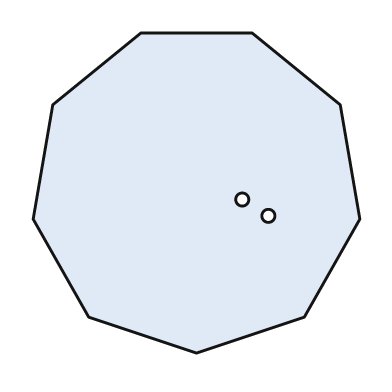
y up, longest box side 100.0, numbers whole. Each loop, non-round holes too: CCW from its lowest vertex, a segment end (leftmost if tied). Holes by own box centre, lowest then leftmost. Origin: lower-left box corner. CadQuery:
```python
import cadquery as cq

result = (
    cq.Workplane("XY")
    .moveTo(50.0, 0.0)
    .lineTo(83.0, 11.0)
    .lineTo(100.0, 41.0)
    .lineTo(94.0, 76.0)
    .lineTo(67.0, 98.0)
    .lineTo(33.0, 98.0)
    .lineTo(6.0, 76.0)
    .lineTo(0.0, 41.0)
    .lineTo(17.0, 11.0)
    .close()
    .moveTo(72.0, 42.0)
    .circle(2.0)
    .moveTo(64.0, 47.0)
    .circle(2.0)
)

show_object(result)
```